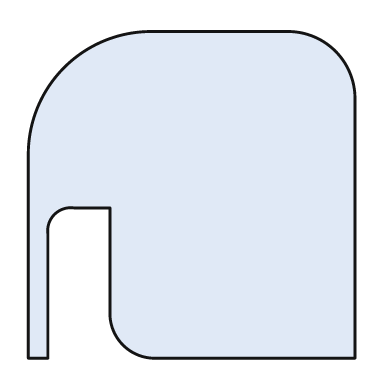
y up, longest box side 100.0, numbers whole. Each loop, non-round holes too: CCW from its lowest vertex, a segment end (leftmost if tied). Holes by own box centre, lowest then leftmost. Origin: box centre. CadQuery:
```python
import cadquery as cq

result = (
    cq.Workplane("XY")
    .moveTo(-50.0, -50.0)
    .lineTo(-44.0, -50.0)
    .lineTo(-44.0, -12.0)
    .threePointArc((-42.0, -6.0), (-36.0, -4.0))
    .lineTo(-25.0, -4.0)
    .lineTo(-25.0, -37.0)
    .threePointArc((-21.0, -46.0), (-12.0, -50.0))
    .lineTo(50.0, -50.0)
    .lineTo(50.0, 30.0)
    .threePointArc((44.0, 44.0), (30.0, 50.0))
    .lineTo(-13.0, 50.0)
    .threePointArc((-39.0, 39.0), (-50.0, 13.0))
    .close()
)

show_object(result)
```